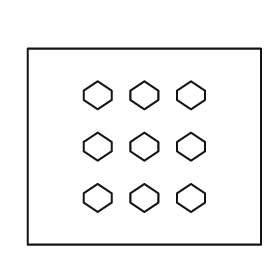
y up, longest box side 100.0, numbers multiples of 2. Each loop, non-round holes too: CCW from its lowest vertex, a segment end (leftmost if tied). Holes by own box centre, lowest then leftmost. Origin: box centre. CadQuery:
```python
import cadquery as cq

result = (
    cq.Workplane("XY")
    .moveTo(-50.0, -42.0)
    .lineTo(50.0, -42.0)
    .lineTo(50.0, 42.0)
    .lineTo(-50.0, 42.0)
    .close()
    .moveTo(-20.0, -28.0)
    .lineTo(-14.0, -24.0)
    .lineTo(-14.0, -20.0)
    .lineTo(-20.0, -16.0)
    .lineTo(-26.0, -20.0)
    .lineTo(-26.0, -24.0)
    .close()
    .moveTo(0.0, -28.0)
    .lineTo(6.0, -24.0)
    .lineTo(6.0, -20.0)
    .lineTo(0.0, -16.0)
    .lineTo(-6.0, -20.0)
    .lineTo(-6.0, -24.0)
    .close()
    .moveTo(20.0, -28.0)
    .lineTo(26.0, -24.0)
    .lineTo(26.0, -20.0)
    .lineTo(20.0, -16.0)
    .lineTo(14.0, -20.0)
    .lineTo(14.0, -24.0)
    .close()
    .moveTo(-20.0, -6.0)
    .lineTo(-14.0, -2.0)
    .lineTo(-14.0, 2.0)
    .lineTo(-20.0, 6.0)
    .lineTo(-26.0, 2.0)
    .lineTo(-26.0, -2.0)
    .close()
    .moveTo(0.0, -6.0)
    .lineTo(6.0, -2.0)
    .lineTo(6.0, 2.0)
    .lineTo(0.0, 6.0)
    .lineTo(-6.0, 2.0)
    .lineTo(-6.0, -2.0)
    .close()
    .moveTo(20.0, -6.0)
    .lineTo(26.0, -2.0)
    .lineTo(26.0, 2.0)
    .lineTo(20.0, 6.0)
    .lineTo(14.0, 2.0)
    .lineTo(14.0, -2.0)
    .close()
    .moveTo(-20.0, 16.0)
    .lineTo(-14.0, 20.0)
    .lineTo(-14.0, 24.0)
    .lineTo(-20.0, 28.0)
    .lineTo(-26.0, 24.0)
    .lineTo(-26.0, 20.0)
    .close()
    .moveTo(0.0, 16.0)
    .lineTo(6.0, 20.0)
    .lineTo(6.0, 24.0)
    .lineTo(0.0, 28.0)
    .lineTo(-6.0, 24.0)
    .lineTo(-6.0, 20.0)
    .close()
    .moveTo(20.0, 16.0)
    .lineTo(26.0, 20.0)
    .lineTo(26.0, 24.0)
    .lineTo(20.0, 28.0)
    .lineTo(14.0, 24.0)
    .lineTo(14.0, 20.0)
    .close()
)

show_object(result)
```